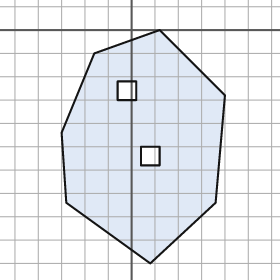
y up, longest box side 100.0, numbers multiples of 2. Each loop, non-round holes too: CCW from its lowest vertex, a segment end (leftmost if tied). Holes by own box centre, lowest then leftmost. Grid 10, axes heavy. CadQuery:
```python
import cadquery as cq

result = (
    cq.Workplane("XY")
    .moveTo(8.0, -100.0)
    .lineTo(36.0, -74.0)
    .lineTo(40.0, -28.0)
    .lineTo(12.0, 0.0)
    .lineTo(-16.0, -10.0)
    .lineTo(-30.0, -44.0)
    .lineTo(-28.0, -74.0)
    .close()
    .moveTo(4.0, -58.0)
    .lineTo(12.0, -58.0)
    .lineTo(12.0, -50.0)
    .lineTo(4.0, -50.0)
    .close()
    .moveTo(-6.0, -30.0)
    .lineTo(2.0, -30.0)
    .lineTo(2.0, -22.0)
    .lineTo(-6.0, -22.0)
    .close()
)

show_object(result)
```